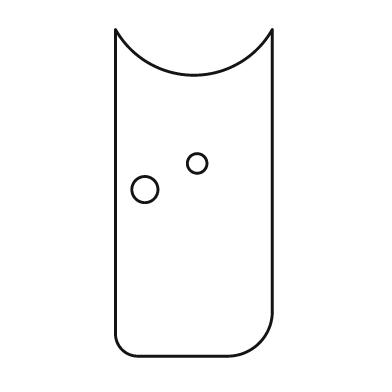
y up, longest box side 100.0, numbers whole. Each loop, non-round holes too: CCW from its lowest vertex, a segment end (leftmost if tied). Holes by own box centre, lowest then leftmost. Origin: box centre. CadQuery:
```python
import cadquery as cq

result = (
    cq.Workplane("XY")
    .moveTo(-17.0, -50.0)
    .lineTo(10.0, -50.0)
    .threePointArc((20.0, -46.0), (24.0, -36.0))
    .lineTo(24.0, 50.0)
    .threePointArc((0.0, 36.0), (-24.0, 50.0))
    .lineTo(-24.0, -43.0)
    .threePointArc((-22.0, -48.0), (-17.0, -50.0))
    .close()
    .moveTo(-15.0, 1.0)
    .circle(4.0)
    .moveTo(1.0, 9.0)
    .circle(3.0)
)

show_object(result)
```